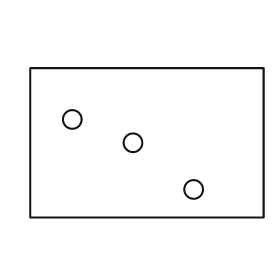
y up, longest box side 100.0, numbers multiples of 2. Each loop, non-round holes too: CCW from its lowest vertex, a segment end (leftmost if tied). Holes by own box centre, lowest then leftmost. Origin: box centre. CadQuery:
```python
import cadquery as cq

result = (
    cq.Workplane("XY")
    .moveTo(-50.0, -32.0)
    .lineTo(50.0, -32.0)
    .lineTo(50.0, 32.0)
    .lineTo(-50.0, 32.0)
    .close()
    .moveTo(20.0, -20.0)
    .circle(4.0)
    .moveTo(-6.0, 0.0)
    .circle(4.0)
    .moveTo(-32.0, 10.0)
    .circle(4.0)
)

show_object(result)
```